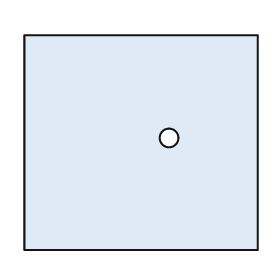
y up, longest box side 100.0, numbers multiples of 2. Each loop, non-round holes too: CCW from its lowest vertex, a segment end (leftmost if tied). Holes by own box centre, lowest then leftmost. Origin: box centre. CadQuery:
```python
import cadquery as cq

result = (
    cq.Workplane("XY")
    .moveTo(-50.0, -46.0)
    .lineTo(50.0, -46.0)
    .lineTo(50.0, 46.0)
    .lineTo(-50.0, 46.0)
    .close()
    .moveTo(12.0, 2.0)
    .circle(4.0)
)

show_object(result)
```